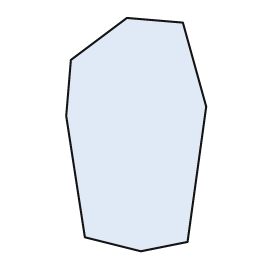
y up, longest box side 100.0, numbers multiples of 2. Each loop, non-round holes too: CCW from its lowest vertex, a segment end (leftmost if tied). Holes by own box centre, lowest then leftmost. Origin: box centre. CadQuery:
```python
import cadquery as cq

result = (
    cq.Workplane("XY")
    .moveTo(2.0, -50.0)
    .lineTo(22.0, -46.0)
    .lineTo(30.0, 12.0)
    .lineTo(20.0, 48.0)
    .lineTo(-4.0, 50.0)
    .lineTo(-28.0, 32.0)
    .lineTo(-30.0, 8.0)
    .lineTo(-22.0, -44.0)
    .close()
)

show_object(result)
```